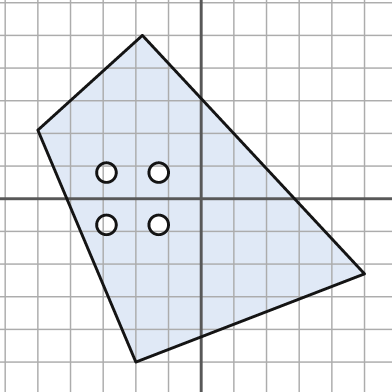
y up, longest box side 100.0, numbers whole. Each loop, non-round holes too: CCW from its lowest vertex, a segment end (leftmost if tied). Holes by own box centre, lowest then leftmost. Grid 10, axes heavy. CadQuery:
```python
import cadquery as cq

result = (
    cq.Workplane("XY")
    .moveTo(-20.0, -50.0)
    .lineTo(50.0, -23.0)
    .lineTo(-18.0, 50.0)
    .lineTo(-50.0, 21.0)
    .close()
    .moveTo(-29.0, -8.0)
    .circle(3.0)
    .moveTo(-13.0, -8.0)
    .circle(3.0)
    .moveTo(-29.0, 8.0)
    .circle(3.0)
    .moveTo(-13.0, 8.0)
    .circle(3.0)
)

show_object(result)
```